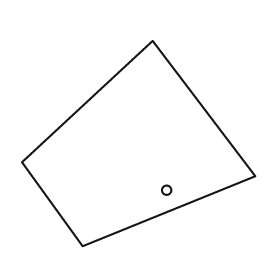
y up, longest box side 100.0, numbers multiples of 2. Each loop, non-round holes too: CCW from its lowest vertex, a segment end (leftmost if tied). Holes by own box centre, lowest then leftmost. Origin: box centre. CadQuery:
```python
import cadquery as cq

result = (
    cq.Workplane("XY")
    .moveTo(-24.0, -44.0)
    .lineTo(50.0, -14.0)
    .lineTo(6.0, 44.0)
    .lineTo(-50.0, -8.0)
    .close()
    .moveTo(12.0, -20.0)
    .circle(2.0)
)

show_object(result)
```